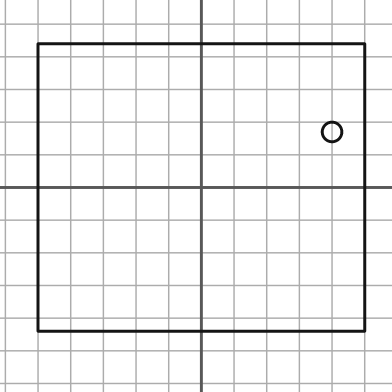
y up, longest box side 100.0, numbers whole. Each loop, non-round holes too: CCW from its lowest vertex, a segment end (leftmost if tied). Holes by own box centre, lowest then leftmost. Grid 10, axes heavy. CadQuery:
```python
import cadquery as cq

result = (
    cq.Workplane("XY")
    .moveTo(-50.0, -44.0)
    .lineTo(50.0, -44.0)
    .lineTo(50.0, 44.0)
    .lineTo(-50.0, 44.0)
    .close()
    .moveTo(40.0, 17.0)
    .circle(3.0)
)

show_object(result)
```